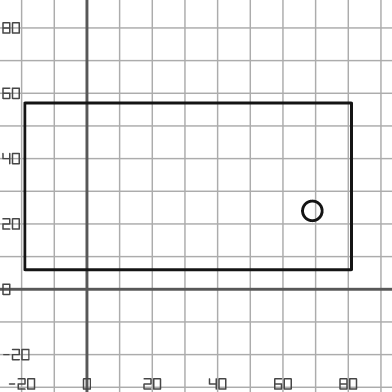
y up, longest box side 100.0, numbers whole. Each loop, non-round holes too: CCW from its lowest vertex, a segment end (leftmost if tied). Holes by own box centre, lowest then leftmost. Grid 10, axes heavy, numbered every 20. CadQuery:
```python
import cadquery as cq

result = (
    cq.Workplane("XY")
    .moveTo(-19.0, 6.0)
    .lineTo(81.0, 6.0)
    .lineTo(81.0, 57.0)
    .lineTo(-19.0, 57.0)
    .close()
    .moveTo(69.0, 24.0)
    .circle(3.0)
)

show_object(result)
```